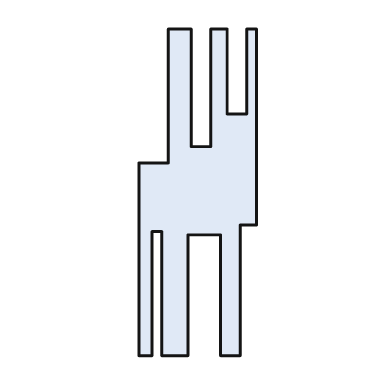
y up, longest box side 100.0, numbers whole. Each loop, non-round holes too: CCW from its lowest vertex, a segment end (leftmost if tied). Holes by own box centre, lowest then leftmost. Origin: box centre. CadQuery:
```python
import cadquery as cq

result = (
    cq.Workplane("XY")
    .moveTo(-18.0, -50.0)
    .lineTo(-14.0, -50.0)
    .lineTo(-14.0, -12.0)
    .lineTo(-11.0, -12.0)
    .lineTo(-11.0, -50.0)
    .lineTo(-3.0, -50.0)
    .lineTo(-3.0, -13.0)
    .lineTo(7.0, -13.0)
    .lineTo(7.0, -50.0)
    .lineTo(13.0, -50.0)
    .lineTo(13.0, -10.0)
    .lineTo(18.0, -10.0)
    .lineTo(18.0, 50.0)
    .lineTo(15.0, 50.0)
    .lineTo(15.0, 24.0)
    .lineTo(9.0, 24.0)
    .lineTo(9.0, 50.0)
    .lineTo(4.0, 50.0)
    .lineTo(4.0, 14.0)
    .lineTo(-2.0, 14.0)
    .lineTo(-2.0, 50.0)
    .lineTo(-9.0, 50.0)
    .lineTo(-9.0, 9.0)
    .lineTo(-18.0, 9.0)
    .close()
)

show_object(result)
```